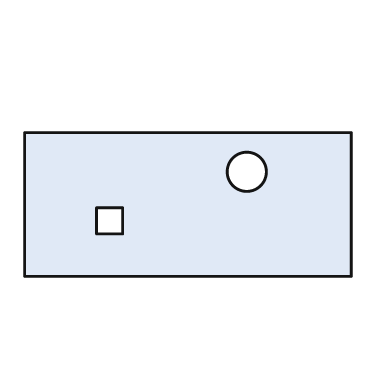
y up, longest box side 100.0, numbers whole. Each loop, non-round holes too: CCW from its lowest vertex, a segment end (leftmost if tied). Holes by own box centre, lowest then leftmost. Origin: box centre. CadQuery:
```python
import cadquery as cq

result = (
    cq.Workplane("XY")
    .moveTo(-50.0, -22.0)
    .lineTo(50.0, -22.0)
    .lineTo(50.0, 22.0)
    .lineTo(-50.0, 22.0)
    .close()
    .moveTo(-28.0, -9.0)
    .lineTo(-20.0, -9.0)
    .lineTo(-20.0, -1.0)
    .lineTo(-28.0, -1.0)
    .close()
    .moveTo(18.0, 10.0)
    .circle(6.0)
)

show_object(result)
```